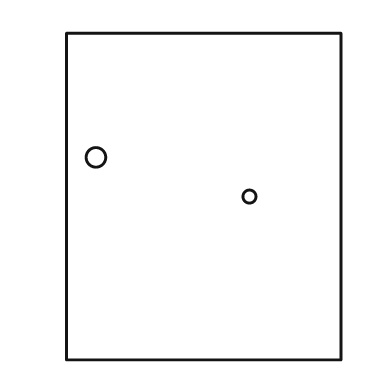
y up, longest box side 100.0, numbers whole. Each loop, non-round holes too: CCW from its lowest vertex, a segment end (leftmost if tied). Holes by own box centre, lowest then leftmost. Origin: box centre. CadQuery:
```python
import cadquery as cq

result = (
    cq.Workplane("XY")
    .moveTo(-42.0, -50.0)
    .lineTo(42.0, -50.0)
    .lineTo(42.0, 50.0)
    .lineTo(-42.0, 50.0)
    .close()
    .moveTo(14.0, 0.0)
    .circle(2.0)
    .moveTo(-33.0, 12.0)
    .circle(3.0)
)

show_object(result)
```